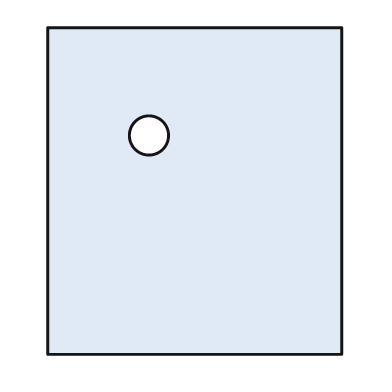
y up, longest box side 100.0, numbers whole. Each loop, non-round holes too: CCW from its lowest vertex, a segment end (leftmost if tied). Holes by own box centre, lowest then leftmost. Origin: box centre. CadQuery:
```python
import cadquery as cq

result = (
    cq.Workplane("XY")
    .moveTo(-45.0, -50.0)
    .lineTo(45.0, -50.0)
    .lineTo(45.0, 50.0)
    .lineTo(-45.0, 50.0)
    .close()
    .moveTo(-14.0, 17.0)
    .circle(6.0)
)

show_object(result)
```